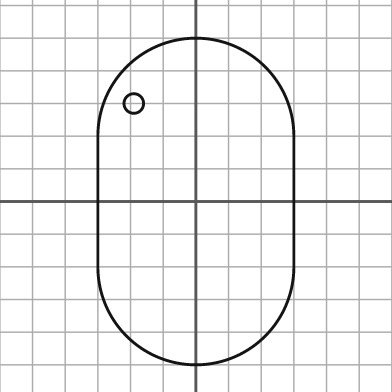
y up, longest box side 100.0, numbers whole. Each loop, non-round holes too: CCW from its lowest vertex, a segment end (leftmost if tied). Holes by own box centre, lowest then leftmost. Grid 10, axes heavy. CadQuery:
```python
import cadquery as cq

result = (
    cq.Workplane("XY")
    .moveTo(-30.0, -20.0)
    .threePointArc((0.0, -50.0), (30.0, -20.0))
    .lineTo(30.0, 20.0)
    .threePointArc((0.0, 50.0), (-30.0, 20.0))
    .close()
    .moveTo(-19.0, 30.0)
    .circle(3.0)
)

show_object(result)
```